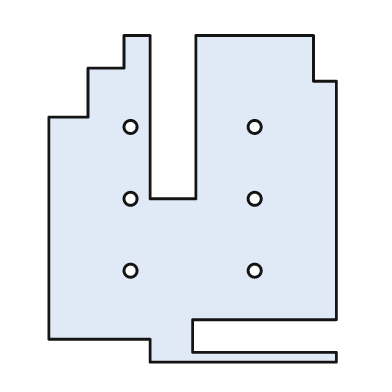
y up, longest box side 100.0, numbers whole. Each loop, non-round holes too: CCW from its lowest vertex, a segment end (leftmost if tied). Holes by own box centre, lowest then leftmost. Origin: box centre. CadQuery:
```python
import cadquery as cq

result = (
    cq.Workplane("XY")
    .moveTo(-13.0, -50.0)
    .lineTo(44.0, -50.0)
    .lineTo(44.0, -47.0)
    .lineTo(0.0, -47.0)
    .lineTo(0.0, -37.0)
    .lineTo(44.0, -37.0)
    .lineTo(44.0, 36.0)
    .lineTo(37.0, 36.0)
    .lineTo(37.0, 50.0)
    .lineTo(1.0, 50.0)
    .lineTo(1.0, 0.0)
    .lineTo(-13.0, 0.0)
    .lineTo(-13.0, 50.0)
    .lineTo(-21.0, 50.0)
    .lineTo(-21.0, 40.0)
    .lineTo(-32.0, 40.0)
    .lineTo(-32.0, 25.0)
    .lineTo(-44.0, 25.0)
    .lineTo(-44.0, -43.0)
    .lineTo(-13.0, -43.0)
    .close()
    .moveTo(-19.0, -22.0)
    .circle(2.0)
    .moveTo(19.0, -22.0)
    .circle(2.0)
    .moveTo(-19.0, 0.0)
    .circle(2.0)
    .moveTo(19.0, 0.0)
    .circle(2.0)
    .moveTo(-19.0, 22.0)
    .circle(2.0)
    .moveTo(19.0, 22.0)
    .circle(2.0)
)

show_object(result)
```